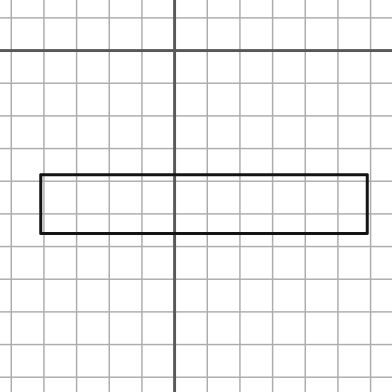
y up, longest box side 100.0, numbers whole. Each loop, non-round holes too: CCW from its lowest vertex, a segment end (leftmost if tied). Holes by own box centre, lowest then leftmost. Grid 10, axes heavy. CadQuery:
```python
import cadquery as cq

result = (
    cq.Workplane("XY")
    .moveTo(-41.0, -56.0)
    .lineTo(59.0, -56.0)
    .lineTo(59.0, -38.0)
    .lineTo(-41.0, -38.0)
    .close()
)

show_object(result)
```